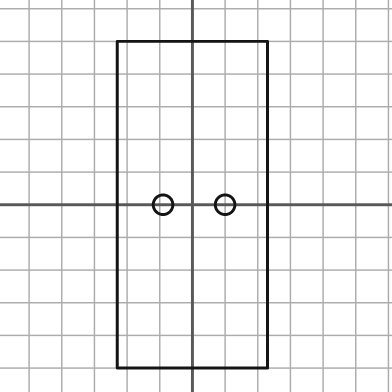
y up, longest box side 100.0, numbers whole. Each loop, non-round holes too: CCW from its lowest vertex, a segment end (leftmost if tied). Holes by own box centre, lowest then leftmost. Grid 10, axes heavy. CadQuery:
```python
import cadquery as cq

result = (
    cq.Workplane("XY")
    .moveTo(-23.0, -50.0)
    .lineTo(23.0, -50.0)
    .lineTo(23.0, 50.0)
    .lineTo(-23.0, 50.0)
    .close()
    .moveTo(-9.0, 0.0)
    .circle(3.0)
    .moveTo(10.0, 0.0)
    .circle(3.0)
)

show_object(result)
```